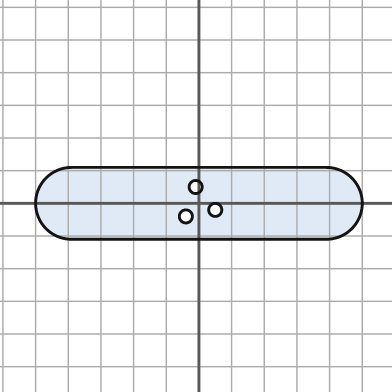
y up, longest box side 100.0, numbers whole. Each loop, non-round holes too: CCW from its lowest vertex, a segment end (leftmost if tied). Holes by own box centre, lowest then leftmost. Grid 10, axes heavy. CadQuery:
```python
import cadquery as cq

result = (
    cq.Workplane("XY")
    .moveTo(-39.0, -11.0)
    .lineTo(39.0, -11.0)
    .threePointArc((50.0, 0.0), (39.0, 11.0))
    .lineTo(-39.0, 11.0)
    .threePointArc((-50.0, 0.0), (-39.0, -11.0))
    .close()
    .moveTo(-4.0, -4.0)
    .circle(2.0)
    .moveTo(5.0, -2.0)
    .circle(2.0)
    .moveTo(-1.0, 5.0)
    .circle(2.0)
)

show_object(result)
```